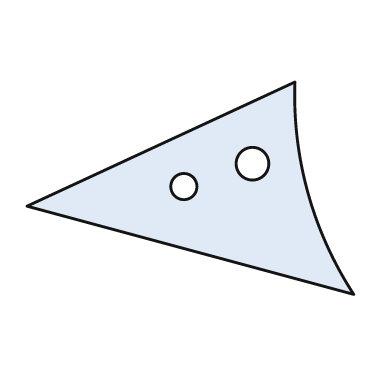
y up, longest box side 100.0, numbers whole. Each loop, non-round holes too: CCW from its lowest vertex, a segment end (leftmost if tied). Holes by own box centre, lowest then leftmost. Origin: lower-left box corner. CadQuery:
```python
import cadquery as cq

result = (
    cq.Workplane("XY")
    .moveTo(100.0, 0.0)
    .threePointArc((86.0, 31.0), (82.0, 65.0))
    .lineTo(0.0, 27.0)
    .close()
    .moveTo(48.0, 33.0)
    .circle(4.0)
    .moveTo(69.0, 40.0)
    .circle(5.0)
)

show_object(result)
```